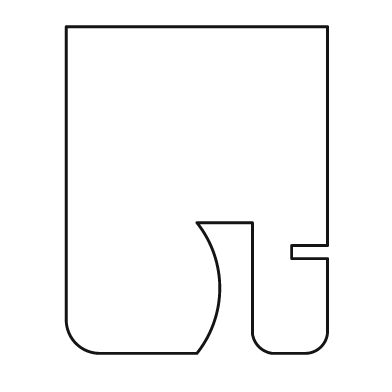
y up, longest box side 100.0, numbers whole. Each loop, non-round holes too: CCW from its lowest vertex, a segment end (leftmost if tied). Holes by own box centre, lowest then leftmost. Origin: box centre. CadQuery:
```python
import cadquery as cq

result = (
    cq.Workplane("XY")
    .moveTo(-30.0, -50.0)
    .lineTo(0.0, -50.0)
    .threePointArc((7.0, -30.0), (0.0, -10.0))
    .lineTo(17.0, -10.0)
    .lineTo(17.0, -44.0)
    .threePointArc((19.0, -48.0), (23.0, -50.0))
    .lineTo(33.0, -50.0)
    .threePointArc((38.0, -48.0), (40.0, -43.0))
    .lineTo(40.0, -21.0)
    .lineTo(29.0, -21.0)
    .lineTo(29.0, -17.0)
    .lineTo(40.0, -17.0)
    .lineTo(40.0, 50.0)
    .lineTo(-40.0, 50.0)
    .lineTo(-40.0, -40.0)
    .threePointArc((-37.0, -47.0), (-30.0, -50.0))
    .close()
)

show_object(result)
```